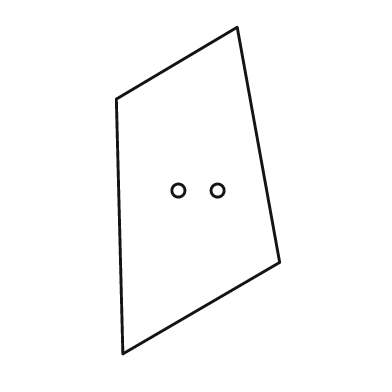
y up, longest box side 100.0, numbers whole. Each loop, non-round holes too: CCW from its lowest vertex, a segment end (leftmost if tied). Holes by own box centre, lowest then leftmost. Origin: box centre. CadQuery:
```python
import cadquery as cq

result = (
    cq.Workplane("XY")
    .moveTo(-23.0, -50.0)
    .lineTo(25.0, -22.0)
    .lineTo(12.0, 50.0)
    .lineTo(-25.0, 28.0)
    .close()
    .moveTo(-6.0, 0.0)
    .circle(2.0)
    .moveTo(6.0, 0.0)
    .circle(2.0)
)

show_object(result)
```